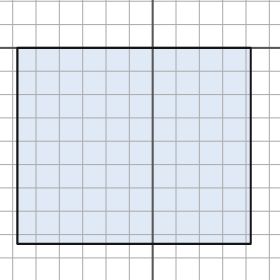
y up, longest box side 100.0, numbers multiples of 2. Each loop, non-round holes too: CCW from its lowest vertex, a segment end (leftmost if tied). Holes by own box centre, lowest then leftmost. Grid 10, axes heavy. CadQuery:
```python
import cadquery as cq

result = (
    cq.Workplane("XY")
    .moveTo(-58.0, -84.0)
    .lineTo(42.0, -84.0)
    .lineTo(42.0, 0.0)
    .lineTo(-58.0, 0.0)
    .close()
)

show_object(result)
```